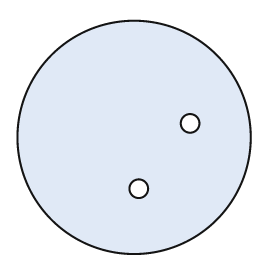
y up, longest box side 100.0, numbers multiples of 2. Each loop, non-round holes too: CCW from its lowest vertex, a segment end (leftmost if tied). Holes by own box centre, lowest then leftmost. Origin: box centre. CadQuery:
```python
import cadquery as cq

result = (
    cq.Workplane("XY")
    .moveTo(0.0, 0.0)
    .circle(50.0)
    .moveTo(2.0, -22.0)
    .circle(4.0)
    .moveTo(24.0, 6.0)
    .circle(4.0)
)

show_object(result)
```